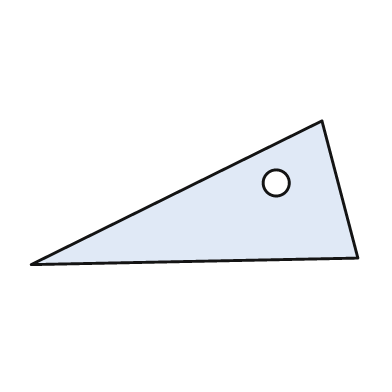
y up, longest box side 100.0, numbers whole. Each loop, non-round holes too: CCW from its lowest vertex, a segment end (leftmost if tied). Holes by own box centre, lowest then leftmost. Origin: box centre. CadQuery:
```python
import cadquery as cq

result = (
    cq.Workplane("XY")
    .moveTo(-50.0, -22.0)
    .lineTo(50.0, -20.0)
    .lineTo(39.0, 22.0)
    .close()
    .moveTo(25.0, 3.0)
    .circle(4.0)
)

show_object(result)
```